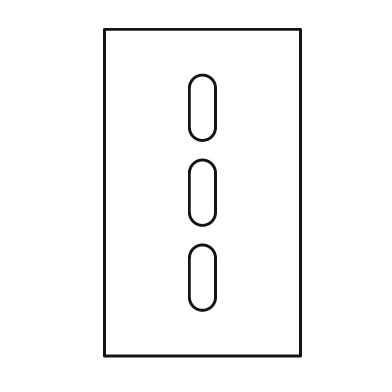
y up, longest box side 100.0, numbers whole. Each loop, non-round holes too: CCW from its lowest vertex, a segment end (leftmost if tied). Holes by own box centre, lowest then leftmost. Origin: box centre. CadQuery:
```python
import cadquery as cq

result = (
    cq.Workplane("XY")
    .moveTo(-30.0, -50.0)
    .lineTo(30.0, -50.0)
    .lineTo(30.0, 50.0)
    .lineTo(-30.0, 50.0)
    .close()
    .moveTo(-4.0, -32.0)
    .threePointArc((0.0, -36.0), (4.0, -32.0))
    .lineTo(4.0, -20.0)
    .threePointArc((0.0, -16.0), (-4.0, -20.0))
    .close()
    .moveTo(-4.0, -6.0)
    .threePointArc((0.0, -10.0), (4.0, -6.0))
    .lineTo(4.0, 6.0)
    .threePointArc((0.0, 10.0), (-4.0, 6.0))
    .close()
    .moveTo(-4.0, 20.0)
    .threePointArc((0.0, 16.0), (4.0, 20.0))
    .lineTo(4.0, 32.0)
    .threePointArc((0.0, 36.0), (-4.0, 32.0))
    .close()
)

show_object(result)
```